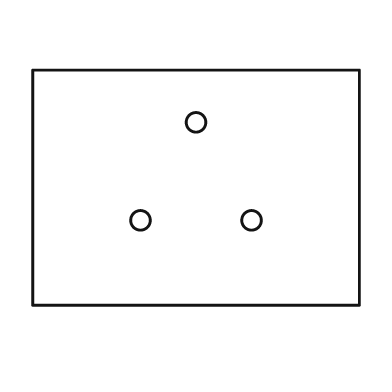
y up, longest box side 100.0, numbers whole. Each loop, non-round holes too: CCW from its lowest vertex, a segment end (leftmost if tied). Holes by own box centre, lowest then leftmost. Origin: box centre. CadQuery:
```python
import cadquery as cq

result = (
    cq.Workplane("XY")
    .moveTo(-50.0, -36.0)
    .lineTo(50.0, -36.0)
    .lineTo(50.0, 36.0)
    .lineTo(-50.0, 36.0)
    .close()
    .moveTo(-17.0, -10.0)
    .circle(3.0)
    .moveTo(17.0, -10.0)
    .circle(3.0)
    .moveTo(0.0, 20.0)
    .circle(3.0)
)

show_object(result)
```